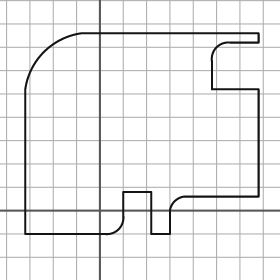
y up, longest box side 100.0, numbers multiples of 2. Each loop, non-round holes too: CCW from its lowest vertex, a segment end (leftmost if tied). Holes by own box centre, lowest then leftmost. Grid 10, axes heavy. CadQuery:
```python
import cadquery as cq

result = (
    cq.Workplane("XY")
    .moveTo(-32.0, -10.0)
    .lineTo(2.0, -10.0)
    .threePointArc((8.0, -8.0), (10.0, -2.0))
    .lineTo(10.0, 8.0)
    .lineTo(22.0, 8.0)
    .lineTo(22.0, -10.0)
    .lineTo(30.0, -10.0)
    .lineTo(30.0, 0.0)
    .threePointArc((32.0, 4.0), (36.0, 6.0))
    .lineTo(68.0, 6.0)
    .lineTo(68.0, 52.0)
    .lineTo(48.0, 52.0)
    .lineTo(48.0, 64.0)
    .threePointArc((50.0, 70.0), (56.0, 72.0))
    .lineTo(68.0, 72.0)
    .lineTo(68.0, 76.0)
    .lineTo(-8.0, 76.0)
    .threePointArc((-24.0, 68.0), (-32.0, 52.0))
    .close()
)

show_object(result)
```